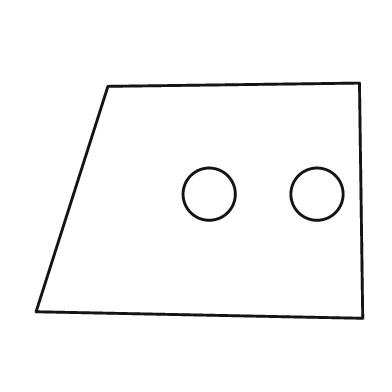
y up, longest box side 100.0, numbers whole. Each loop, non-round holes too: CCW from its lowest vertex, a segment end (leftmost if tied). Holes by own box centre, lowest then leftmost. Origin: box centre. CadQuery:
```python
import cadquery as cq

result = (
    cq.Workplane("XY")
    .moveTo(50.0, -36.0)
    .lineTo(49.0, 36.0)
    .lineTo(-28.0, 35.0)
    .lineTo(-50.0, -34.0)
    .close()
    .moveTo(3.0, 2.0)
    .circle(8.0)
    .moveTo(36.0, 2.0)
    .circle(8.0)
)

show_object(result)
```